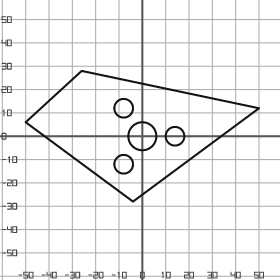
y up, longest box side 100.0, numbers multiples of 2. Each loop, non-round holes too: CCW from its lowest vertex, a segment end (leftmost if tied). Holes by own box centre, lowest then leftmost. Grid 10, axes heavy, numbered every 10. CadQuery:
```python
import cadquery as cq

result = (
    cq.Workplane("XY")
    .moveTo(-4.0, -28.0)
    .lineTo(50.0, 12.0)
    .lineTo(-26.0, 28.0)
    .lineTo(-50.0, 6.0)
    .close()
    .moveTo(-8.0, -12.0)
    .circle(4.0)
    .moveTo(0.0, 0.0)
    .circle(6.0)
    .moveTo(14.0, 0.0)
    .circle(4.0)
    .moveTo(-8.0, 12.0)
    .circle(4.0)
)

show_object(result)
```